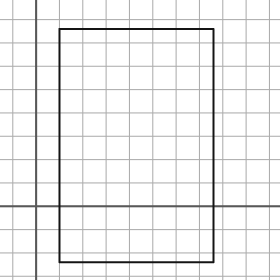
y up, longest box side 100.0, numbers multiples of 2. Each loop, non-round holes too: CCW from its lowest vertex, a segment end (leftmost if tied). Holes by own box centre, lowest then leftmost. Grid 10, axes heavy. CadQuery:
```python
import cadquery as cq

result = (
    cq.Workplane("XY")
    .moveTo(10.0, -24.0)
    .lineTo(76.0, -24.0)
    .lineTo(76.0, 76.0)
    .lineTo(10.0, 76.0)
    .close()
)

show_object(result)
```